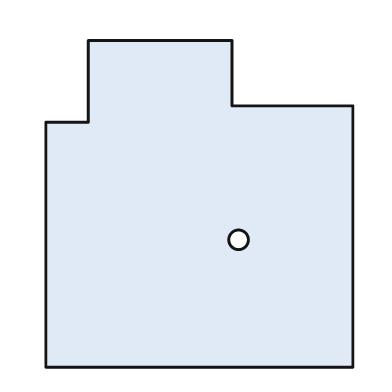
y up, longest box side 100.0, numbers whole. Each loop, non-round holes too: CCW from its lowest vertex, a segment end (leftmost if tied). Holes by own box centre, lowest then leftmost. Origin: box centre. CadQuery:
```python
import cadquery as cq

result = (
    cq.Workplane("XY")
    .moveTo(-47.0, -50.0)
    .lineTo(47.0, -50.0)
    .lineTo(47.0, 30.0)
    .lineTo(10.0, 30.0)
    .lineTo(10.0, 50.0)
    .lineTo(-34.0, 50.0)
    .lineTo(-34.0, 25.0)
    .lineTo(-47.0, 25.0)
    .close()
    .moveTo(12.0, -11.0)
    .circle(3.0)
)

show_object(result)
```